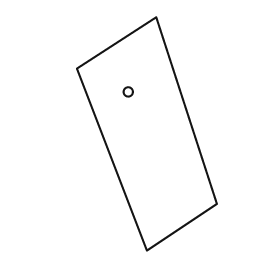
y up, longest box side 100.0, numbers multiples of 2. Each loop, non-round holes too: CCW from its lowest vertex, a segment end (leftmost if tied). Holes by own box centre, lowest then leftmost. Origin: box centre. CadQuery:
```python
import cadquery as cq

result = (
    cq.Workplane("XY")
    .moveTo(0.0, -50.0)
    .lineTo(30.0, -30.0)
    .lineTo(4.0, 50.0)
    .lineTo(-30.0, 28.0)
    .close()
    .moveTo(-8.0, 18.0)
    .circle(2.0)
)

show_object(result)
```